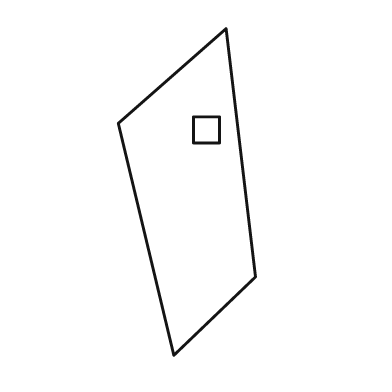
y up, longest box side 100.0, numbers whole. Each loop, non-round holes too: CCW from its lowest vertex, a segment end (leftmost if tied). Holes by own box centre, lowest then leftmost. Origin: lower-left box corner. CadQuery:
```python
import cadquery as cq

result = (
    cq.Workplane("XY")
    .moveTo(17.0, 0.0)
    .lineTo(42.0, 24.0)
    .lineTo(33.0, 100.0)
    .lineTo(0.0, 71.0)
    .close()
    .moveTo(23.0, 65.0)
    .lineTo(31.0, 65.0)
    .lineTo(31.0, 73.0)
    .lineTo(23.0, 73.0)
    .close()
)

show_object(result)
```